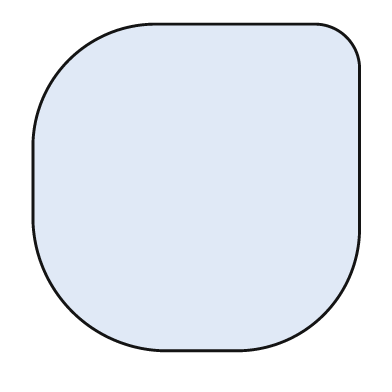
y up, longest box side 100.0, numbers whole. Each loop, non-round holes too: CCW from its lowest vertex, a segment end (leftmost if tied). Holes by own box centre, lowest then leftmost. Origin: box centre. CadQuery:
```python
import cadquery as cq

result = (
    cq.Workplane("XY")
    .moveTo(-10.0, -50.0)
    .lineTo(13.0, -50.0)
    .threePointArc((39.0, -39.0), (50.0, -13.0))
    .lineTo(50.0, 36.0)
    .threePointArc((46.0, 46.0), (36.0, 50.0))
    .lineTo(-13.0, 50.0)
    .threePointArc((-39.0, 39.0), (-50.0, 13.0))
    .lineTo(-50.0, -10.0)
    .threePointArc((-38.0, -38.0), (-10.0, -50.0))
    .close()
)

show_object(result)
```